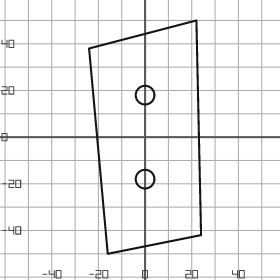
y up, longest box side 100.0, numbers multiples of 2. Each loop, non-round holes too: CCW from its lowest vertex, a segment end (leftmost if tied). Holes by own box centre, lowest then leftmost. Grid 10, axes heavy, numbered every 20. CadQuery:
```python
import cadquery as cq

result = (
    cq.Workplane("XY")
    .moveTo(-16.0, -50.0)
    .lineTo(24.0, -42.0)
    .lineTo(22.0, 50.0)
    .lineTo(-24.0, 38.0)
    .close()
    .moveTo(0.0, -18.0)
    .circle(4.0)
    .moveTo(0.0, 18.0)
    .circle(4.0)
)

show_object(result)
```